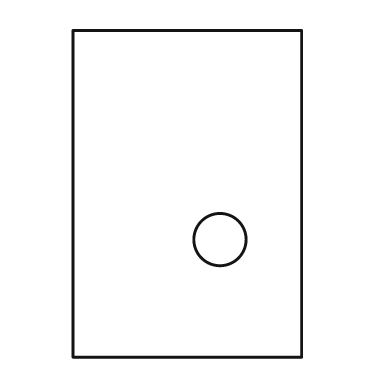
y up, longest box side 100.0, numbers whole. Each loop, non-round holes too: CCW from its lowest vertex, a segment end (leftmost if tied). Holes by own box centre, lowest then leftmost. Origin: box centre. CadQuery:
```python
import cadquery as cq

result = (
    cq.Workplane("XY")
    .moveTo(-35.0, -50.0)
    .lineTo(35.0, -50.0)
    .lineTo(35.0, 50.0)
    .lineTo(-35.0, 50.0)
    .close()
    .moveTo(10.0, -14.0)
    .circle(8.0)
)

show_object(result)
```